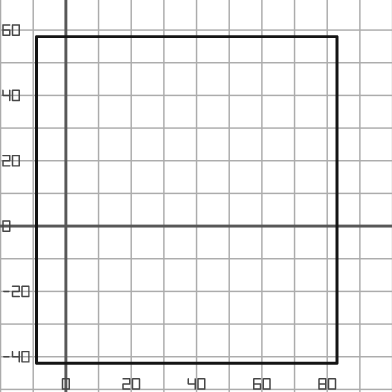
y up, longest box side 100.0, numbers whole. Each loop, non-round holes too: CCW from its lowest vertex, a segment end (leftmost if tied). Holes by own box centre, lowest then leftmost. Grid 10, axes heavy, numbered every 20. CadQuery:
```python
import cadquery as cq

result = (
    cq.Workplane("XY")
    .moveTo(-9.0, -42.0)
    .lineTo(83.0, -42.0)
    .lineTo(83.0, 58.0)
    .lineTo(-9.0, 58.0)
    .close()
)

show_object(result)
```